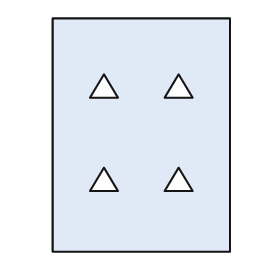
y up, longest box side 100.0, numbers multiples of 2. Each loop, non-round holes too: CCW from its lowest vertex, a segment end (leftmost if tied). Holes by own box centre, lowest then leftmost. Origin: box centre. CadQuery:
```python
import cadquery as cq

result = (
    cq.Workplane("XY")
    .moveTo(-38.0, -50.0)
    .lineTo(38.0, -50.0)
    .lineTo(38.0, 50.0)
    .lineTo(-38.0, 50.0)
    .close()
    .moveTo(-22.0, -24.0)
    .lineTo(-10.0, -24.0)
    .lineTo(-16.0, -14.0)
    .close()
    .moveTo(10.0, -24.0)
    .lineTo(22.0, -24.0)
    .lineTo(16.0, -14.0)
    .close()
    .moveTo(-22.0, 16.0)
    .lineTo(-10.0, 16.0)
    .lineTo(-16.0, 26.0)
    .close()
    .moveTo(10.0, 16.0)
    .lineTo(22.0, 16.0)
    .lineTo(16.0, 26.0)
    .close()
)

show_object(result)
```